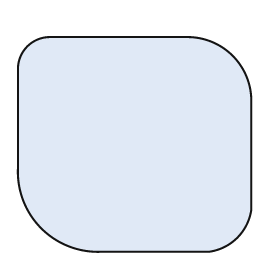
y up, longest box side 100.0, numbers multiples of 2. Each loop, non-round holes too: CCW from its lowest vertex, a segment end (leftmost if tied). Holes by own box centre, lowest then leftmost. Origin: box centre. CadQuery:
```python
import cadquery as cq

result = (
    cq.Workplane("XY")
    .moveTo(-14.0, -46.0)
    .lineTo(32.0, -46.0)
    .threePointArc((44.0, -40.0), (50.0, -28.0))
    .lineTo(50.0, 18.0)
    .threePointArc((42.0, 38.0), (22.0, 46.0))
    .lineTo(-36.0, 46.0)
    .threePointArc((-46.0, 42.0), (-50.0, 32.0))
    .lineTo(-50.0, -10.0)
    .threePointArc((-40.0, -36.0), (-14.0, -46.0))
    .close()
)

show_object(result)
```